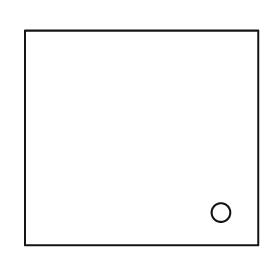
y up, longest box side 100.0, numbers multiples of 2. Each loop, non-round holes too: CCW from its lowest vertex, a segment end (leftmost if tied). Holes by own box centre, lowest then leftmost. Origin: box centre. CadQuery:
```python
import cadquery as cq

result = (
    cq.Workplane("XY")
    .moveTo(-50.0, -46.0)
    .lineTo(50.0, -46.0)
    .lineTo(50.0, 46.0)
    .lineTo(-50.0, 46.0)
    .close()
    .moveTo(34.0, -32.0)
    .circle(4.0)
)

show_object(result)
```